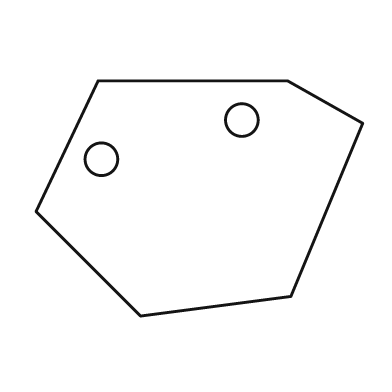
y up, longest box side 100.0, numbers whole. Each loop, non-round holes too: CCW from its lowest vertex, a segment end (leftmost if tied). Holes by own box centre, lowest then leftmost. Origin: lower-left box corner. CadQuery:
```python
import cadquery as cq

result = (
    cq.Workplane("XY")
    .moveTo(32.0, 0.0)
    .lineTo(78.0, 6.0)
    .lineTo(100.0, 59.0)
    .lineTo(77.0, 72.0)
    .lineTo(19.0, 72.0)
    .lineTo(0.0, 32.0)
    .close()
    .moveTo(20.0, 48.0)
    .circle(5.0)
    .moveTo(63.0, 60.0)
    .circle(5.0)
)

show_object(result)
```